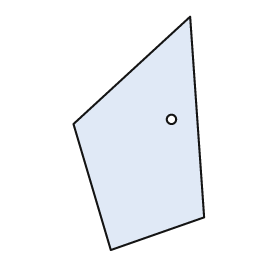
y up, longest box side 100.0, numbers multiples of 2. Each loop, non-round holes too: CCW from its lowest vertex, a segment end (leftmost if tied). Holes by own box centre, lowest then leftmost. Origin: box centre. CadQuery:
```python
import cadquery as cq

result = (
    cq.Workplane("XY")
    .moveTo(-12.0, -50.0)
    .lineTo(28.0, -36.0)
    .lineTo(22.0, 50.0)
    .lineTo(-28.0, 4.0)
    .close()
    .moveTo(14.0, 6.0)
    .circle(2.0)
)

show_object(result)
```